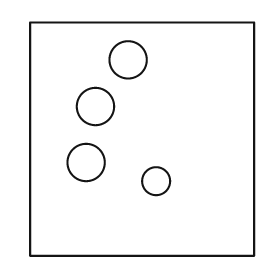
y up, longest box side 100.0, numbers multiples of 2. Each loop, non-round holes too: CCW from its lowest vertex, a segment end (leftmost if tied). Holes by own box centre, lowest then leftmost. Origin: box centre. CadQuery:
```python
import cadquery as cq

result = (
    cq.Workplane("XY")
    .moveTo(-48.0, -50.0)
    .lineTo(48.0, -50.0)
    .lineTo(48.0, 50.0)
    .lineTo(-48.0, 50.0)
    .close()
    .moveTo(6.0, -18.0)
    .circle(6.0)
    .moveTo(-24.0, -10.0)
    .circle(8.0)
    .moveTo(-20.0, 14.0)
    .circle(8.0)
    .moveTo(-6.0, 34.0)
    .circle(8.0)
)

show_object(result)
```